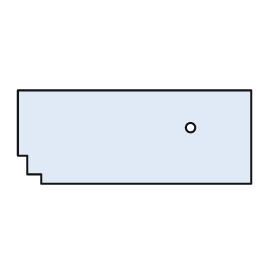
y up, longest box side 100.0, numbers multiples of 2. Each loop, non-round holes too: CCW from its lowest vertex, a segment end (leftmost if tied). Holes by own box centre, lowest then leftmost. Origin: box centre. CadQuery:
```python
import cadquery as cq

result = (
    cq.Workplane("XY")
    .moveTo(-40.0, -20.0)
    .lineTo(50.0, -20.0)
    .lineTo(50.0, 20.0)
    .lineTo(-50.0, 20.0)
    .lineTo(-50.0, -8.0)
    .lineTo(-46.0, -8.0)
    .lineTo(-46.0, -16.0)
    .lineTo(-40.0, -16.0)
    .close()
    .moveTo(24.0, 4.0)
    .circle(2.0)
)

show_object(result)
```